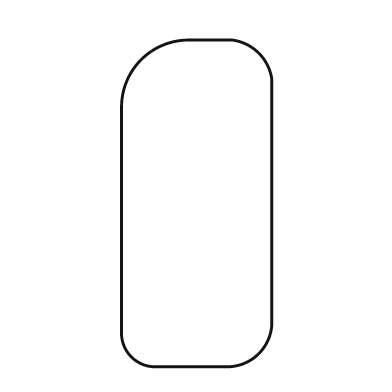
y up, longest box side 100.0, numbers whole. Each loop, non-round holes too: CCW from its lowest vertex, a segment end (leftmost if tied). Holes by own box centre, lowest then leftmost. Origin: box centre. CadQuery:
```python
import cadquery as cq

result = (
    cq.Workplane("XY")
    .moveTo(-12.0, -50.0)
    .lineTo(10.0, -50.0)
    .threePointArc((19.0, -46.0), (23.0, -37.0))
    .lineTo(23.0, 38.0)
    .threePointArc((19.0, 46.0), (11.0, 50.0))
    .lineTo(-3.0, 50.0)
    .threePointArc((-17.0, 44.0), (-23.0, 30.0))
    .lineTo(-23.0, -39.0)
    .threePointArc((-20.0, -47.0), (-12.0, -50.0))
    .close()
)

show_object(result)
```